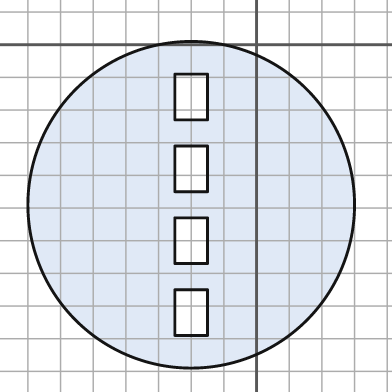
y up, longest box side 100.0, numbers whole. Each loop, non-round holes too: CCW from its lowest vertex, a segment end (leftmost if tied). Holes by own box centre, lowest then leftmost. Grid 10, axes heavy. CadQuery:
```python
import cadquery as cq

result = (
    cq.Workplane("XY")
    .moveTo(-20.0, -49.0)
    .circle(50.0)
    .moveTo(-25.0, -89.0)
    .lineTo(-15.0, -89.0)
    .lineTo(-15.0, -75.0)
    .lineTo(-25.0, -75.0)
    .close()
    .moveTo(-25.0, -67.0)
    .lineTo(-15.0, -67.0)
    .lineTo(-15.0, -53.0)
    .lineTo(-25.0, -53.0)
    .close()
    .moveTo(-25.0, -45.0)
    .lineTo(-15.0, -45.0)
    .lineTo(-15.0, -31.0)
    .lineTo(-25.0, -31.0)
    .close()
    .moveTo(-25.0, -23.0)
    .lineTo(-15.0, -23.0)
    .lineTo(-15.0, -9.0)
    .lineTo(-25.0, -9.0)
    .close()
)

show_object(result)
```